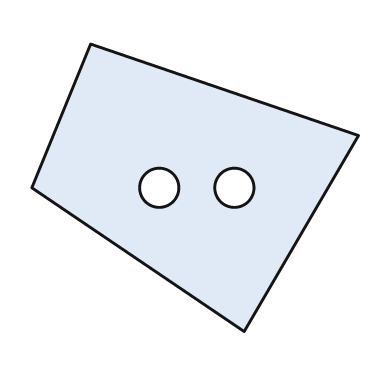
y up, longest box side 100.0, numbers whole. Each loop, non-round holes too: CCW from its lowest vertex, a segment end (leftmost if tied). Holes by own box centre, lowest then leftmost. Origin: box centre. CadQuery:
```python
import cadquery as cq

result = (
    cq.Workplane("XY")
    .moveTo(15.0, -44.0)
    .lineTo(50.0, 16.0)
    .lineTo(-32.0, 44.0)
    .lineTo(-50.0, 0.0)
    .close()
    .moveTo(-11.0, 0.0)
    .circle(6.0)
    .moveTo(12.0, 0.0)
    .circle(6.0)
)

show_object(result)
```